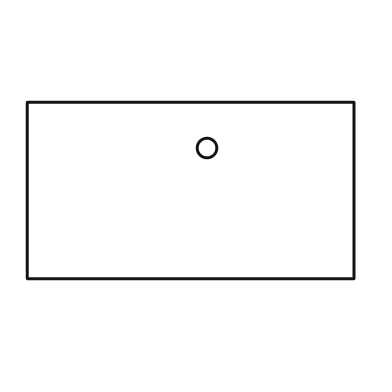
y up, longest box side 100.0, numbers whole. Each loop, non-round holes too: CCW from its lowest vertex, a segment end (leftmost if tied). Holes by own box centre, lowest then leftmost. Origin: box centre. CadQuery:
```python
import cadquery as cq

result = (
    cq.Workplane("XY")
    .moveTo(-50.0, -27.0)
    .lineTo(50.0, -27.0)
    .lineTo(50.0, 27.0)
    .lineTo(-50.0, 27.0)
    .close()
    .moveTo(5.0, 13.0)
    .circle(3.0)
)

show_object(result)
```